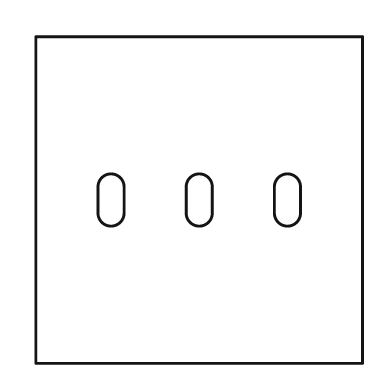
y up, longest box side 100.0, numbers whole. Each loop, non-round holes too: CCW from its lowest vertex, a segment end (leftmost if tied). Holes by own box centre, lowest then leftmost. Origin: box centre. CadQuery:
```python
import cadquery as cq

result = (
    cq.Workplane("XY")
    .moveTo(-50.0, -50.0)
    .lineTo(50.0, -50.0)
    .lineTo(50.0, 50.0)
    .lineTo(-50.0, 50.0)
    .close()
    .moveTo(-31.0, -4.0)
    .threePointArc((-27.0, -8.0), (-23.0, -4.0))
    .lineTo(-23.0, 4.0)
    .threePointArc((-27.0, 8.0), (-31.0, 4.0))
    .close()
    .moveTo(-4.0, -4.0)
    .threePointArc((0.0, -8.0), (4.0, -4.0))
    .lineTo(4.0, 4.0)
    .threePointArc((0.0, 8.0), (-4.0, 4.0))
    .close()
    .moveTo(23.0, -4.0)
    .threePointArc((27.0, -8.0), (31.0, -4.0))
    .lineTo(31.0, 4.0)
    .threePointArc((27.0, 8.0), (23.0, 4.0))
    .close()
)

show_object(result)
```